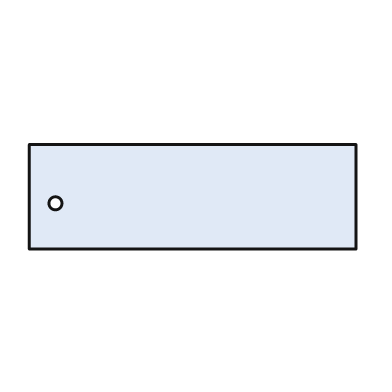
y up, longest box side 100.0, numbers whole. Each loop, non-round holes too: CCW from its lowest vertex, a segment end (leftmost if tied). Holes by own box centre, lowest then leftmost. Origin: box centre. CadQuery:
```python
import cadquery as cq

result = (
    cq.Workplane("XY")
    .moveTo(-50.0, -16.0)
    .lineTo(50.0, -16.0)
    .lineTo(50.0, 16.0)
    .lineTo(-50.0, 16.0)
    .close()
    .moveTo(-42.0, -2.0)
    .circle(2.0)
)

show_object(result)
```